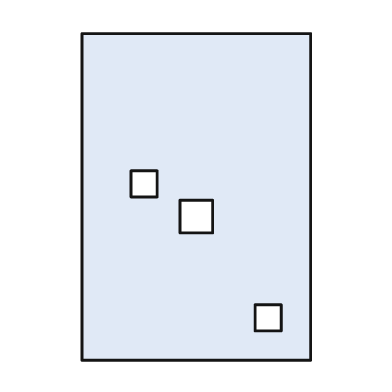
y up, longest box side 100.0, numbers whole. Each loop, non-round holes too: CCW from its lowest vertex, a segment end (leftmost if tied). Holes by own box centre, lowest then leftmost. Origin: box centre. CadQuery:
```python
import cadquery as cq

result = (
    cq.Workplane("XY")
    .moveTo(-35.0, -50.0)
    .lineTo(35.0, -50.0)
    .lineTo(35.0, 50.0)
    .lineTo(-35.0, 50.0)
    .close()
    .moveTo(18.0, -41.0)
    .lineTo(26.0, -41.0)
    .lineTo(26.0, -33.0)
    .lineTo(18.0, -33.0)
    .close()
    .moveTo(-5.0, -11.0)
    .lineTo(5.0, -11.0)
    .lineTo(5.0, -1.0)
    .lineTo(-5.0, -1.0)
    .close()
    .moveTo(-20.0, 0.0)
    .lineTo(-12.0, 0.0)
    .lineTo(-12.0, 8.0)
    .lineTo(-20.0, 8.0)
    .close()
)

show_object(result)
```